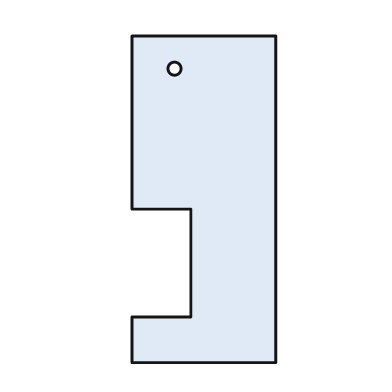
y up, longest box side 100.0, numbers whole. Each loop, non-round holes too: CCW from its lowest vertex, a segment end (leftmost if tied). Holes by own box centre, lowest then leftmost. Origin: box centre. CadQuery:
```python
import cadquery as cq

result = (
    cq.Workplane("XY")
    .moveTo(-22.0, -50.0)
    .lineTo(22.0, -50.0)
    .lineTo(22.0, 50.0)
    .lineTo(-22.0, 50.0)
    .lineTo(-22.0, -3.0)
    .lineTo(-4.0, -3.0)
    .lineTo(-4.0, -36.0)
    .lineTo(-22.0, -36.0)
    .close()
    .moveTo(-9.0, 40.0)
    .circle(2.0)
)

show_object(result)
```